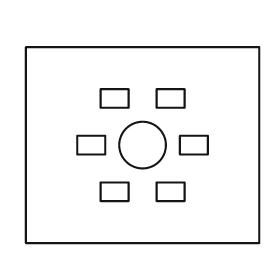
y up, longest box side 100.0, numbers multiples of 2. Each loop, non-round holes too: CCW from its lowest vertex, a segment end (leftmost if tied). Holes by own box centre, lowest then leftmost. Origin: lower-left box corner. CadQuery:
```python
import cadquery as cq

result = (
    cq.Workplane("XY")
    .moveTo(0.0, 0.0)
    .lineTo(100.0, 0.0)
    .lineTo(100.0, 84.0)
    .lineTo(0.0, 84.0)
    .close()
    .moveTo(32.0, 18.0)
    .lineTo(44.0, 18.0)
    .lineTo(44.0, 26.0)
    .lineTo(32.0, 26.0)
    .close()
    .moveTo(56.0, 18.0)
    .lineTo(68.0, 18.0)
    .lineTo(68.0, 26.0)
    .lineTo(56.0, 26.0)
    .close()
    .moveTo(22.0, 38.0)
    .lineTo(34.0, 38.0)
    .lineTo(34.0, 46.0)
    .lineTo(22.0, 46.0)
    .close()
    .moveTo(50.0, 42.0)
    .circle(10.0)
    .moveTo(66.0, 38.0)
    .lineTo(78.0, 38.0)
    .lineTo(78.0, 46.0)
    .lineTo(66.0, 46.0)
    .close()
    .moveTo(32.0, 58.0)
    .lineTo(44.0, 58.0)
    .lineTo(44.0, 66.0)
    .lineTo(32.0, 66.0)
    .close()
    .moveTo(56.0, 58.0)
    .lineTo(68.0, 58.0)
    .lineTo(68.0, 66.0)
    .lineTo(56.0, 66.0)
    .close()
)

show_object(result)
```